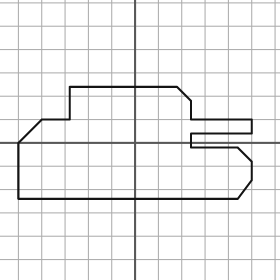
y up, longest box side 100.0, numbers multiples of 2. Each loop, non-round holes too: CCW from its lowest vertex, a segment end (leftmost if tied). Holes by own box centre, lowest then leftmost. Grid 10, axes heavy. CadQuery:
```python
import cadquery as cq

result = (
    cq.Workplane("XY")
    .moveTo(-50.0, -24.0)
    .lineTo(44.0, -24.0)
    .lineTo(50.0, -16.0)
    .lineTo(50.0, -8.0)
    .lineTo(44.0, -2.0)
    .lineTo(24.0, -2.0)
    .lineTo(24.0, 4.0)
    .lineTo(50.0, 4.0)
    .lineTo(50.0, 10.0)
    .lineTo(24.0, 10.0)
    .lineTo(24.0, 18.0)
    .lineTo(18.0, 24.0)
    .lineTo(-28.0, 24.0)
    .lineTo(-28.0, 10.0)
    .lineTo(-40.0, 10.0)
    .lineTo(-50.0, 0.0)
    .close()
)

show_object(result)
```